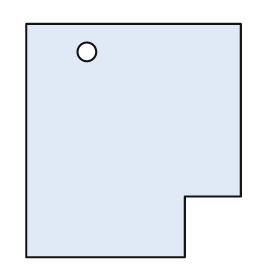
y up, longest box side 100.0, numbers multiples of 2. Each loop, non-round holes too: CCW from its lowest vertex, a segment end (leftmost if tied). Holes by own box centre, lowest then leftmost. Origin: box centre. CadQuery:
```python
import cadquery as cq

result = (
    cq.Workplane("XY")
    .moveTo(-46.0, -50.0)
    .lineTo(22.0, -50.0)
    .lineTo(22.0, -24.0)
    .lineTo(46.0, -24.0)
    .lineTo(46.0, 50.0)
    .lineTo(-46.0, 50.0)
    .close()
    .moveTo(-20.0, 38.0)
    .circle(4.0)
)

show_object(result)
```